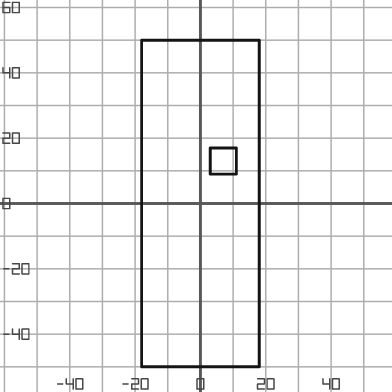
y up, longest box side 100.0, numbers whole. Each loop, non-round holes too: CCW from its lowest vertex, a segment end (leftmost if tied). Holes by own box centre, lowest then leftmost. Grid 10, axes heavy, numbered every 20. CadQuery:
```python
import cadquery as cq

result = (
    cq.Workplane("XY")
    .moveTo(-18.0, -50.0)
    .lineTo(18.0, -50.0)
    .lineTo(18.0, 50.0)
    .lineTo(-18.0, 50.0)
    .close()
    .moveTo(3.0, 9.0)
    .lineTo(11.0, 9.0)
    .lineTo(11.0, 17.0)
    .lineTo(3.0, 17.0)
    .close()
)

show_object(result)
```